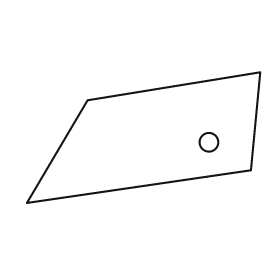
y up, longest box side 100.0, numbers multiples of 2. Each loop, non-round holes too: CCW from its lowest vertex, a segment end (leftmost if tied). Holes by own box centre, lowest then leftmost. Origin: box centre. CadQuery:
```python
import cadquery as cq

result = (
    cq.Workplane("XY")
    .moveTo(-50.0, -28.0)
    .lineTo(46.0, -14.0)
    .lineTo(50.0, 28.0)
    .lineTo(-24.0, 16.0)
    .close()
    .moveTo(28.0, -2.0)
    .circle(4.0)
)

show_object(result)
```